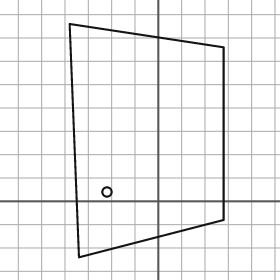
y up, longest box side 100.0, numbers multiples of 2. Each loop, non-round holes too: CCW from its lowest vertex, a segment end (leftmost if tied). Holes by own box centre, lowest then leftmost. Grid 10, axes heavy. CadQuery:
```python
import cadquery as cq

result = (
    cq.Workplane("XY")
    .moveTo(-34.0, -24.0)
    .lineTo(28.0, -8.0)
    .lineTo(28.0, 66.0)
    .lineTo(-38.0, 76.0)
    .close()
    .moveTo(-22.0, 4.0)
    .circle(2.0)
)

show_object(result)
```